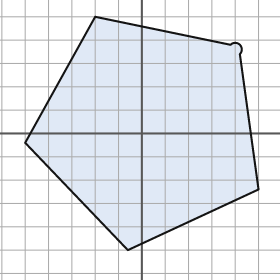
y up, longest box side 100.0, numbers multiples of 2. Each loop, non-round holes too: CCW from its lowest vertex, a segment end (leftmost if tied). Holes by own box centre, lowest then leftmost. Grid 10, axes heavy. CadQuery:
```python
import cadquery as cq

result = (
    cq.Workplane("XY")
    .moveTo(-6.0, -50.0)
    .lineTo(50.0, -24.0)
    .lineTo(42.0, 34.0)
    .threePointArc((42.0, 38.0), (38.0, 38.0))
    .lineTo(-20.0, 50.0)
    .lineTo(-50.0, -4.0)
    .close()
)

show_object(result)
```